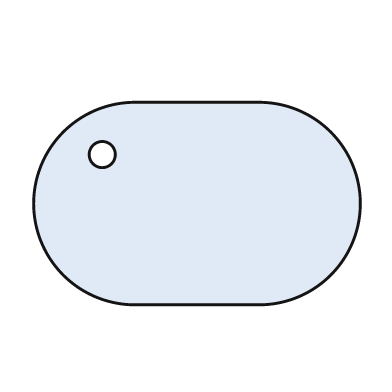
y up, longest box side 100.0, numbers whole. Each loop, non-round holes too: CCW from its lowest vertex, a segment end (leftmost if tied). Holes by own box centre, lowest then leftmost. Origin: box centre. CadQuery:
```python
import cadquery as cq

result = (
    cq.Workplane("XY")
    .moveTo(-19.0, -31.0)
    .lineTo(19.0, -31.0)
    .threePointArc((50.0, 0.0), (19.0, 31.0))
    .lineTo(-19.0, 31.0)
    .threePointArc((-50.0, 0.0), (-19.0, -31.0))
    .close()
    .moveTo(-29.0, 15.0)
    .circle(4.0)
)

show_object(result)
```